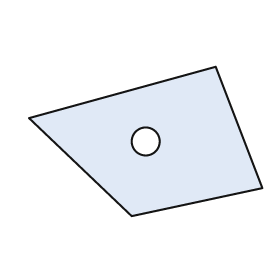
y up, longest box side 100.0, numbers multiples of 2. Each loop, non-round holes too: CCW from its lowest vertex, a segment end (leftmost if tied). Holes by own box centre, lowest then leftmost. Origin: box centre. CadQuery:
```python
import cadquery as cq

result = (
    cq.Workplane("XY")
    .moveTo(-6.0, -32.0)
    .lineTo(50.0, -20.0)
    .lineTo(30.0, 32.0)
    .lineTo(-50.0, 10.0)
    .close()
    .moveTo(0.0, 0.0)
    .circle(6.0)
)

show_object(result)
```